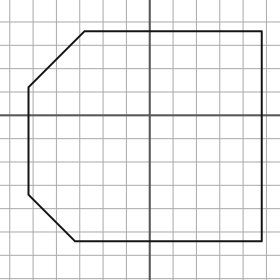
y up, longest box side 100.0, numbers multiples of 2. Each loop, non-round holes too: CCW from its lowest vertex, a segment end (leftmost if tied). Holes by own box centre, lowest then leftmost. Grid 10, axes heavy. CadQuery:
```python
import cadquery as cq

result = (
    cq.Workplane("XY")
    .moveTo(-32.0, -54.0)
    .lineTo(48.0, -54.0)
    .lineTo(48.0, 36.0)
    .lineTo(-28.0, 36.0)
    .lineTo(-52.0, 12.0)
    .lineTo(-52.0, -34.0)
    .close()
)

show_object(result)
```